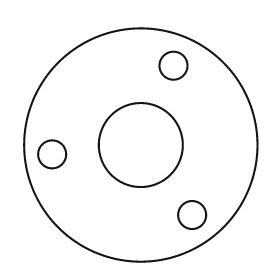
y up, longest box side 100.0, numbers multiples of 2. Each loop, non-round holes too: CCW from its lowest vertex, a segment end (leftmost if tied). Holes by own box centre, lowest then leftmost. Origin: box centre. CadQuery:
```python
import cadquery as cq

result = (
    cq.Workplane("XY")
    .moveTo(0.0, 0.0)
    .circle(50.0)
    .moveTo(22.0, -30.0)
    .circle(6.0)
    .moveTo(-38.0, -4.0)
    .circle(6.0)
    .moveTo(0.0, 0.0)
    .circle(18.0)
    .moveTo(14.0, 34.0)
    .circle(6.0)
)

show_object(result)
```